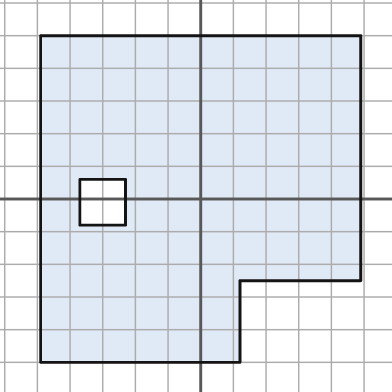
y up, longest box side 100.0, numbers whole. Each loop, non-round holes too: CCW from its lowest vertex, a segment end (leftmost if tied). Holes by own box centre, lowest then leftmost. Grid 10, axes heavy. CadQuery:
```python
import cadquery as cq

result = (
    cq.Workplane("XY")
    .moveTo(-49.0, -50.0)
    .lineTo(12.0, -50.0)
    .lineTo(12.0, -25.0)
    .lineTo(49.0, -25.0)
    .lineTo(49.0, 50.0)
    .lineTo(-49.0, 50.0)
    .close()
    .moveTo(-37.0, -8.0)
    .lineTo(-23.0, -8.0)
    .lineTo(-23.0, 6.0)
    .lineTo(-37.0, 6.0)
    .close()
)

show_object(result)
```